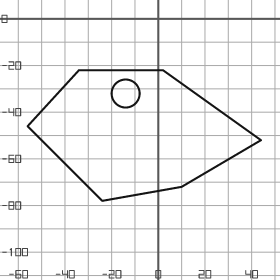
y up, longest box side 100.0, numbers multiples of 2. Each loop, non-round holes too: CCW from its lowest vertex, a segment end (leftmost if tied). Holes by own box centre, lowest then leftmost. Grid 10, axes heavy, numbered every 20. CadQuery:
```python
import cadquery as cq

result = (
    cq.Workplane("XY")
    .moveTo(-24.0, -78.0)
    .lineTo(10.0, -72.0)
    .lineTo(44.0, -52.0)
    .lineTo(2.0, -22.0)
    .lineTo(-34.0, -22.0)
    .lineTo(-56.0, -46.0)
    .close()
    .moveTo(-14.0, -32.0)
    .circle(6.0)
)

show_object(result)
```